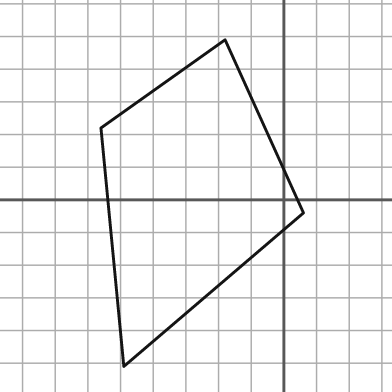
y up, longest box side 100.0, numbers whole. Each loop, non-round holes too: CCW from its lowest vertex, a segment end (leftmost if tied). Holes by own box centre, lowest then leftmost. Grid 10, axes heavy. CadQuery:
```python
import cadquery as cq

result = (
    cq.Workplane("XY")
    .moveTo(-49.0, -51.0)
    .lineTo(6.0, -4.0)
    .lineTo(-18.0, 49.0)
    .lineTo(-56.0, 22.0)
    .close()
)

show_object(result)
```